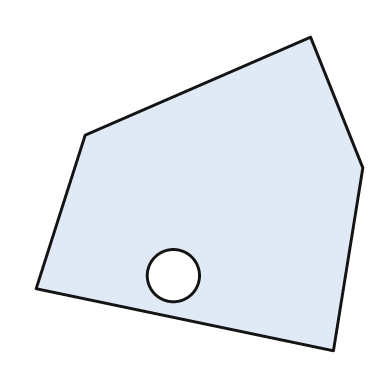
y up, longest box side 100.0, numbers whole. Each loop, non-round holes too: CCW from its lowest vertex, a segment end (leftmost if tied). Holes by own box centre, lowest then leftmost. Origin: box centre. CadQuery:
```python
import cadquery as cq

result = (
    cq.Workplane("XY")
    .moveTo(41.0, -48.0)
    .lineTo(50.0, 8.0)
    .lineTo(34.0, 48.0)
    .lineTo(-35.0, 18.0)
    .lineTo(-50.0, -29.0)
    .close()
    .moveTo(-8.0, -25.0)
    .circle(8.0)
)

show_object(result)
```